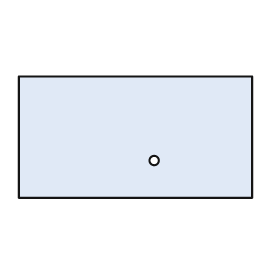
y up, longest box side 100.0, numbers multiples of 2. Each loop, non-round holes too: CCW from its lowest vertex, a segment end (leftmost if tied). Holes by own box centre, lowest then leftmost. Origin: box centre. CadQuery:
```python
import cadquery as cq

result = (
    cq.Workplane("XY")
    .moveTo(-50.0, -26.0)
    .lineTo(50.0, -26.0)
    .lineTo(50.0, 26.0)
    .lineTo(-50.0, 26.0)
    .close()
    .moveTo(8.0, -10.0)
    .circle(2.0)
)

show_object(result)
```